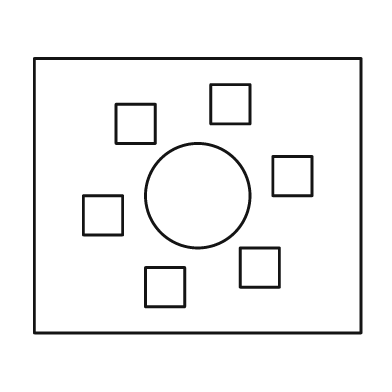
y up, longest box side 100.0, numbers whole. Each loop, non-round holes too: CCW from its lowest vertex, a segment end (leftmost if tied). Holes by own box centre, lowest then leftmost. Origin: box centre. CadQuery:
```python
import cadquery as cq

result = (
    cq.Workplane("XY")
    .moveTo(-50.0, -42.0)
    .lineTo(50.0, -42.0)
    .lineTo(50.0, 42.0)
    .lineTo(-50.0, 42.0)
    .close()
    .moveTo(-16.0, -34.0)
    .lineTo(-4.0, -34.0)
    .lineTo(-4.0, -22.0)
    .lineTo(-16.0, -22.0)
    .close()
    .moveTo(13.0, -28.0)
    .lineTo(25.0, -28.0)
    .lineTo(25.0, -16.0)
    .lineTo(13.0, -16.0)
    .close()
    .moveTo(-35.0, -12.0)
    .lineTo(-23.0, -12.0)
    .lineTo(-23.0, 0.0)
    .lineTo(-35.0, 0.0)
    .close()
    .moveTo(0.0, 0.0)
    .circle(16.0)
    .moveTo(23.0, 0.0)
    .lineTo(35.0, 0.0)
    .lineTo(35.0, 12.0)
    .lineTo(23.0, 12.0)
    .close()
    .moveTo(-25.0, 16.0)
    .lineTo(-13.0, 16.0)
    .lineTo(-13.0, 28.0)
    .lineTo(-25.0, 28.0)
    .close()
    .moveTo(4.0, 22.0)
    .lineTo(16.0, 22.0)
    .lineTo(16.0, 34.0)
    .lineTo(4.0, 34.0)
    .close()
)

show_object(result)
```